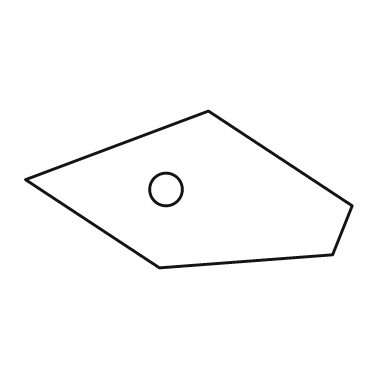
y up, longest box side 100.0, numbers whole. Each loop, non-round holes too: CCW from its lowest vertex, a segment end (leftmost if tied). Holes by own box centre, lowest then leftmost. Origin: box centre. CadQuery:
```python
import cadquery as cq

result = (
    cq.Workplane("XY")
    .moveTo(-9.0, -24.0)
    .lineTo(44.0, -20.0)
    .lineTo(50.0, -5.0)
    .lineTo(6.0, 24.0)
    .lineTo(-50.0, 3.0)
    .close()
    .moveTo(-7.0, 0.0)
    .circle(5.0)
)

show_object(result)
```